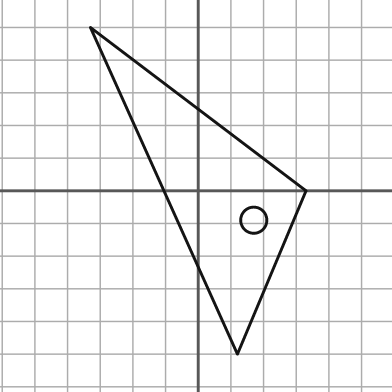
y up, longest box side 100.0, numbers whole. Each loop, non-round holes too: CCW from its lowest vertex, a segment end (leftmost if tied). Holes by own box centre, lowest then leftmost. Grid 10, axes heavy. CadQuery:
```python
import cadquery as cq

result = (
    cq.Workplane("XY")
    .moveTo(12.0, -50.0)
    .lineTo(33.0, 0.0)
    .lineTo(-33.0, 50.0)
    .close()
    .moveTo(17.0, -9.0)
    .circle(4.0)
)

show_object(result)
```